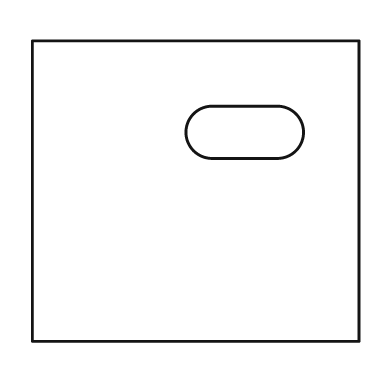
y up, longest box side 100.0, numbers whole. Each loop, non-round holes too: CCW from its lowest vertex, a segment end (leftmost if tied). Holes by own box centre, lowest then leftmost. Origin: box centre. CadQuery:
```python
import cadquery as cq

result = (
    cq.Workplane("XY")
    .moveTo(-50.0, -46.0)
    .lineTo(50.0, -46.0)
    .lineTo(50.0, 46.0)
    .lineTo(-50.0, 46.0)
    .close()
    .moveTo(5.0, 10.0)
    .lineTo(25.0, 10.0)
    .threePointArc((33.0, 18.0), (25.0, 26.0))
    .lineTo(5.0, 26.0)
    .threePointArc((-3.0, 18.0), (5.0, 10.0))
    .close()
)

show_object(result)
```